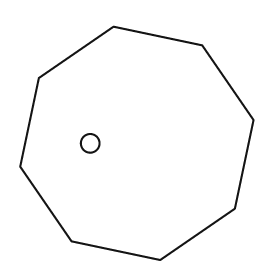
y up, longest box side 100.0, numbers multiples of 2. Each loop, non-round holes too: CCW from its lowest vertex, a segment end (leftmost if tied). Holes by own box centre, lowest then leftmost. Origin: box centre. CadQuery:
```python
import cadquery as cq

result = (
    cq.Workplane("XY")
    .moveTo(10.0, -50.0)
    .lineTo(42.0, -28.0)
    .lineTo(50.0, 10.0)
    .lineTo(28.0, 42.0)
    .lineTo(-10.0, 50.0)
    .lineTo(-42.0, 28.0)
    .lineTo(-50.0, -10.0)
    .lineTo(-28.0, -42.0)
    .close()
    .moveTo(-20.0, 0.0)
    .circle(4.0)
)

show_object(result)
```